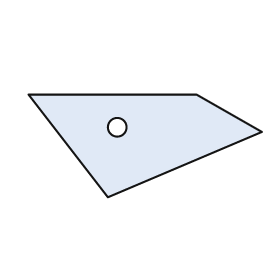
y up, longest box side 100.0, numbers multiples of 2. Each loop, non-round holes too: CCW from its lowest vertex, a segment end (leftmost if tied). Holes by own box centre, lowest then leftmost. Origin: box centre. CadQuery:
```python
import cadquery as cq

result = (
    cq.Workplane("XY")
    .moveTo(-16.0, -22.0)
    .lineTo(50.0, 6.0)
    .lineTo(22.0, 22.0)
    .lineTo(-50.0, 22.0)
    .close()
    .moveTo(-12.0, 8.0)
    .circle(4.0)
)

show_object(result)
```